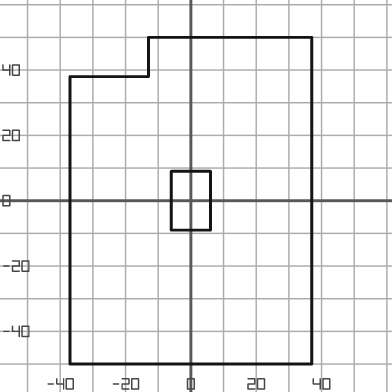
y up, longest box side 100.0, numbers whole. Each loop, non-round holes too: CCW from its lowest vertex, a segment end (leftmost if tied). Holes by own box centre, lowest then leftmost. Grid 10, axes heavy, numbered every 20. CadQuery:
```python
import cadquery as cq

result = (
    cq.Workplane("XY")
    .moveTo(-37.0, -50.0)
    .lineTo(37.0, -50.0)
    .lineTo(37.0, 50.0)
    .lineTo(-13.0, 50.0)
    .lineTo(-13.0, 38.0)
    .lineTo(-37.0, 38.0)
    .close()
    .moveTo(-6.0, -9.0)
    .lineTo(6.0, -9.0)
    .lineTo(6.0, 9.0)
    .lineTo(-6.0, 9.0)
    .close()
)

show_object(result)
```